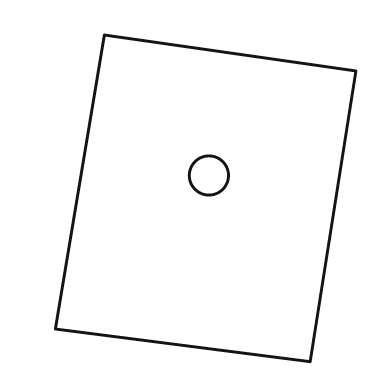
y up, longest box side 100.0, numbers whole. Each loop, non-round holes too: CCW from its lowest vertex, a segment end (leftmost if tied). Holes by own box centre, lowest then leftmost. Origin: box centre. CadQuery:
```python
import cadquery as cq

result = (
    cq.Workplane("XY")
    .moveTo(32.0, -50.0)
    .lineTo(46.0, 39.0)
    .lineTo(-31.0, 50.0)
    .lineTo(-46.0, -40.0)
    .close()
    .moveTo(1.0, 7.0)
    .circle(6.0)
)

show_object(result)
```